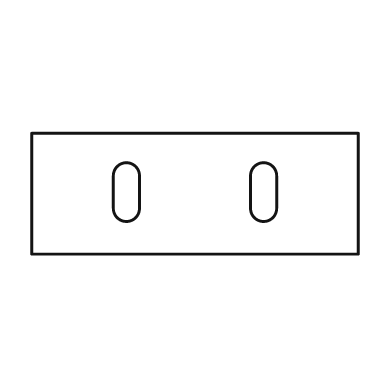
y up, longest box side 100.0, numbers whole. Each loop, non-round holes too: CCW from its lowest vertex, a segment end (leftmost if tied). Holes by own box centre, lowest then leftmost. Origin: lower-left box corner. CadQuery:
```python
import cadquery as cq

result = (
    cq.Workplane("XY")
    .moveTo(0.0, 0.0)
    .lineTo(100.0, 0.0)
    .lineTo(100.0, 37.0)
    .lineTo(0.0, 37.0)
    .close()
    .moveTo(25.0, 14.0)
    .threePointArc((29.0, 10.0), (33.0, 14.0))
    .lineTo(33.0, 24.0)
    .threePointArc((29.0, 28.0), (25.0, 24.0))
    .close()
    .moveTo(67.0, 14.0)
    .threePointArc((71.0, 10.0), (75.0, 14.0))
    .lineTo(75.0, 24.0)
    .threePointArc((71.0, 28.0), (67.0, 24.0))
    .close()
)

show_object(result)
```